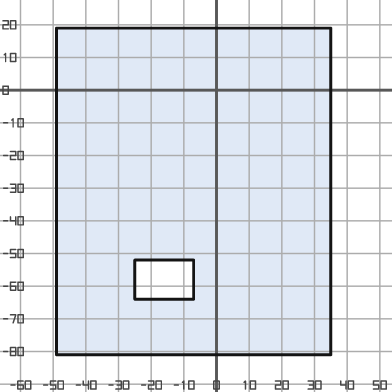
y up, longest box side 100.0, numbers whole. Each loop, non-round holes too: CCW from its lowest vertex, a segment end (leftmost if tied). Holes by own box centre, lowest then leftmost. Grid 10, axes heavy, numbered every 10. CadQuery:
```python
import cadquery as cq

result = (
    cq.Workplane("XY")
    .moveTo(-49.0, -81.0)
    .lineTo(35.0, -81.0)
    .lineTo(35.0, 19.0)
    .lineTo(-49.0, 19.0)
    .close()
    .moveTo(-25.0, -64.0)
    .lineTo(-7.0, -64.0)
    .lineTo(-7.0, -52.0)
    .lineTo(-25.0, -52.0)
    .close()
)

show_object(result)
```